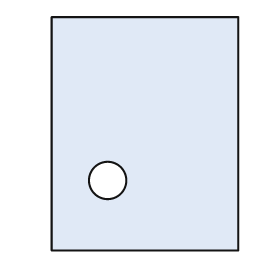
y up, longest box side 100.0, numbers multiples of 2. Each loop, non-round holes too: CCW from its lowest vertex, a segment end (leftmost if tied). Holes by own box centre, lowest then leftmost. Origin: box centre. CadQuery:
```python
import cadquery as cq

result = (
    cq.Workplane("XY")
    .moveTo(-40.0, -50.0)
    .lineTo(40.0, -50.0)
    .lineTo(40.0, 50.0)
    .lineTo(-40.0, 50.0)
    .close()
    .moveTo(-16.0, -20.0)
    .circle(8.0)
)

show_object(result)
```